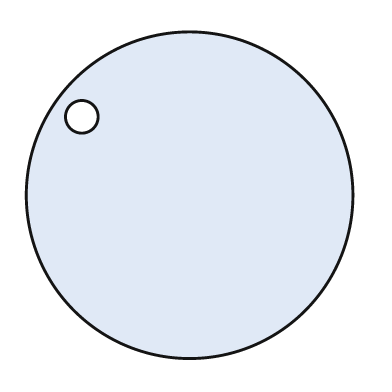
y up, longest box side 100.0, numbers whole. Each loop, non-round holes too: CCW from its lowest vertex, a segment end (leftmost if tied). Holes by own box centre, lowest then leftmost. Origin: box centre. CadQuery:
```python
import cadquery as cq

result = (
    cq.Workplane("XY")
    .moveTo(0.0, 0.0)
    .circle(50.0)
    .moveTo(-33.0, 24.0)
    .circle(5.0)
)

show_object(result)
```